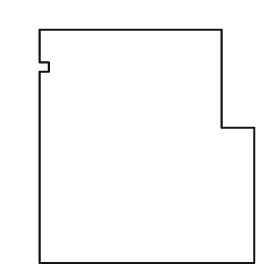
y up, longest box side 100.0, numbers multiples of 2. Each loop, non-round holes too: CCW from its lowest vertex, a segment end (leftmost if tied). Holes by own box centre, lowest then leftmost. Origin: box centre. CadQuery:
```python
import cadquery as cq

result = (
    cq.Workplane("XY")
    .moveTo(-46.0, -50.0)
    .lineTo(46.0, -50.0)
    .lineTo(46.0, 8.0)
    .lineTo(32.0, 8.0)
    .lineTo(32.0, 50.0)
    .lineTo(-46.0, 50.0)
    .lineTo(-46.0, 36.0)
    .lineTo(-42.0, 36.0)
    .lineTo(-42.0, 32.0)
    .lineTo(-46.0, 32.0)
    .close()
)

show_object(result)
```